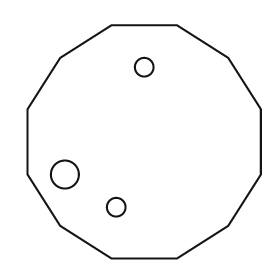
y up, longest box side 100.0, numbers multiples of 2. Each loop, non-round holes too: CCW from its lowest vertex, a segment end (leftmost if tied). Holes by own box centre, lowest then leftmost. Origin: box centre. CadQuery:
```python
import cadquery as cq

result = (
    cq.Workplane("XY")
    .moveTo(-14.0, -50.0)
    .lineTo(14.0, -50.0)
    .lineTo(36.0, -36.0)
    .lineTo(50.0, -14.0)
    .lineTo(50.0, 14.0)
    .lineTo(36.0, 36.0)
    .lineTo(14.0, 50.0)
    .lineTo(-14.0, 50.0)
    .lineTo(-36.0, 36.0)
    .lineTo(-50.0, 14.0)
    .lineTo(-50.0, -14.0)
    .lineTo(-36.0, -36.0)
    .close()
    .moveTo(-12.0, -28.0)
    .circle(4.0)
    .moveTo(-34.0, -14.0)
    .circle(6.0)
    .moveTo(0.0, 32.0)
    .circle(4.0)
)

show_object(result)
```